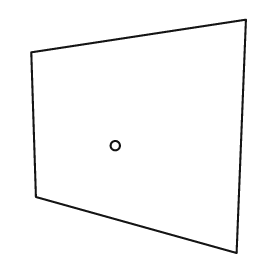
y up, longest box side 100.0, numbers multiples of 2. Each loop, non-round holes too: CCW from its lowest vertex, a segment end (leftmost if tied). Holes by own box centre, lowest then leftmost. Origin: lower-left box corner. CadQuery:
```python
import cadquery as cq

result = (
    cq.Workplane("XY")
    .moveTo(88.0, 0.0)
    .lineTo(92.0, 100.0)
    .lineTo(0.0, 86.0)
    .lineTo(2.0, 24.0)
    .close()
    .moveTo(36.0, 46.0)
    .circle(2.0)
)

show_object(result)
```